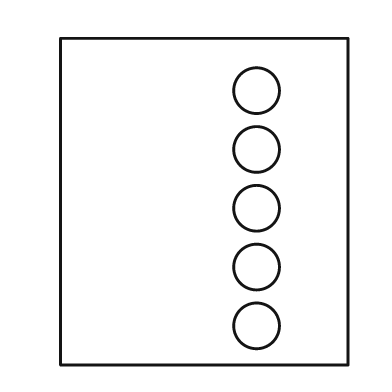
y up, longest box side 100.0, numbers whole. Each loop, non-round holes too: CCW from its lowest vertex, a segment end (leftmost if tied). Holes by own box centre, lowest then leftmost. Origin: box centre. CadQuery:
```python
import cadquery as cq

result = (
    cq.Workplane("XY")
    .moveTo(-44.0, -50.0)
    .lineTo(44.0, -50.0)
    .lineTo(44.0, 50.0)
    .lineTo(-44.0, 50.0)
    .close()
    .moveTo(16.0, -38.0)
    .circle(7.0)
    .moveTo(16.0, -20.0)
    .circle(7.0)
    .moveTo(16.0, -2.0)
    .circle(7.0)
    .moveTo(16.0, 16.0)
    .circle(7.0)
    .moveTo(16.0, 34.0)
    .circle(7.0)
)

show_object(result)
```